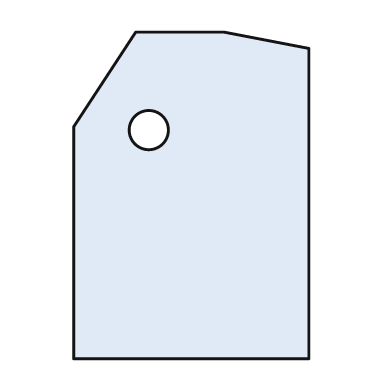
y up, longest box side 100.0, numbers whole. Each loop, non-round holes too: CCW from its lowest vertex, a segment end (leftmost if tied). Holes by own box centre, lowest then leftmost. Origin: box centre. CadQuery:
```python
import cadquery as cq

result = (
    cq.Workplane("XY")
    .moveTo(-36.0, -50.0)
    .lineTo(36.0, -50.0)
    .lineTo(36.0, 45.0)
    .lineTo(10.0, 50.0)
    .lineTo(-17.0, 50.0)
    .lineTo(-36.0, 21.0)
    .close()
    .moveTo(-13.0, 20.0)
    .circle(6.0)
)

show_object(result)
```